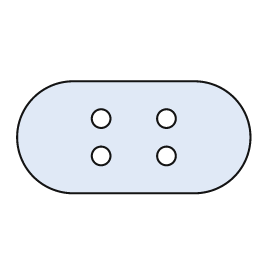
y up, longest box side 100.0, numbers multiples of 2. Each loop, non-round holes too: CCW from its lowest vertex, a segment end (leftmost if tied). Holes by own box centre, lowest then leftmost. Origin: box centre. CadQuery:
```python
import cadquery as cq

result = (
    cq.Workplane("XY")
    .moveTo(-26.0, -24.0)
    .lineTo(26.0, -24.0)
    .threePointArc((50.0, 0.0), (26.0, 24.0))
    .lineTo(-26.0, 24.0)
    .threePointArc((-50.0, 0.0), (-26.0, -24.0))
    .close()
    .moveTo(-14.0, -8.0)
    .circle(4.0)
    .moveTo(14.0, -8.0)
    .circle(4.0)
    .moveTo(-14.0, 8.0)
    .circle(4.0)
    .moveTo(14.0, 8.0)
    .circle(4.0)
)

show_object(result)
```